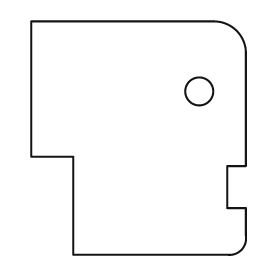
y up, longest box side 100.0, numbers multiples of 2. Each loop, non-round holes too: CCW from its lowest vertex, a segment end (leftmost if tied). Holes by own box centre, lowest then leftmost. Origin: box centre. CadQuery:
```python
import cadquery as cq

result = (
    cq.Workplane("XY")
    .moveTo(-28.0, -50.0)
    .lineTo(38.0, -50.0)
    .threePointArc((44.0, -48.0), (46.0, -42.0))
    .lineTo(46.0, -30.0)
    .lineTo(38.0, -30.0)
    .lineTo(38.0, -12.0)
    .lineTo(46.0, -12.0)
    .lineTo(46.0, 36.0)
    .threePointArc((42.0, 46.0), (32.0, 50.0))
    .lineTo(-46.0, 50.0)
    .lineTo(-46.0, -8.0)
    .lineTo(-28.0, -8.0)
    .close()
    .moveTo(26.0, 20.0)
    .circle(6.0)
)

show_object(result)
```